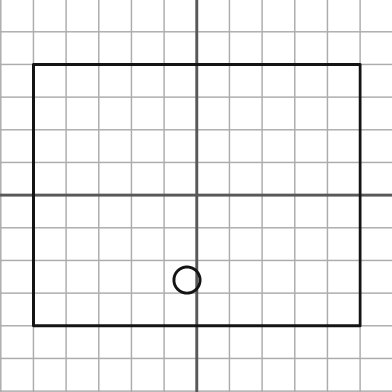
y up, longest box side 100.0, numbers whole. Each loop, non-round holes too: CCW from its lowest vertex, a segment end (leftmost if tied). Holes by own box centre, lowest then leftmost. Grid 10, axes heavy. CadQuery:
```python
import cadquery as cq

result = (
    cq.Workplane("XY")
    .moveTo(-50.0, -40.0)
    .lineTo(50.0, -40.0)
    .lineTo(50.0, 40.0)
    .lineTo(-50.0, 40.0)
    .close()
    .moveTo(-3.0, -26.0)
    .circle(4.0)
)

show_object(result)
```